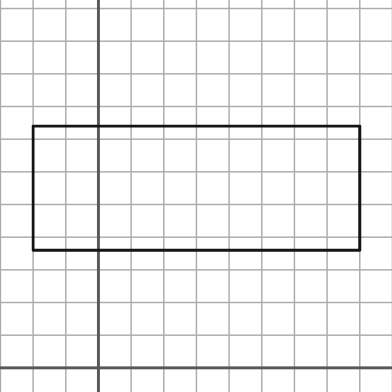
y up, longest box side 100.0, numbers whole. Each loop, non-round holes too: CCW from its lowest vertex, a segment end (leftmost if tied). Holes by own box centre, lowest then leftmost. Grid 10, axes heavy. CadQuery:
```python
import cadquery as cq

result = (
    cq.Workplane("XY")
    .moveTo(-20.0, 36.0)
    .lineTo(80.0, 36.0)
    .lineTo(80.0, 74.0)
    .lineTo(-20.0, 74.0)
    .close()
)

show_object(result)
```